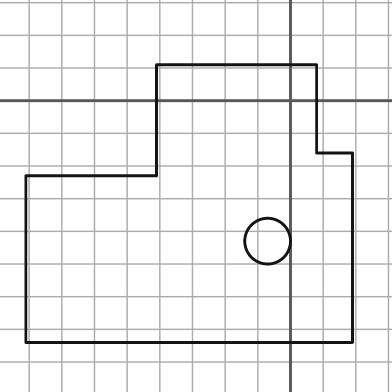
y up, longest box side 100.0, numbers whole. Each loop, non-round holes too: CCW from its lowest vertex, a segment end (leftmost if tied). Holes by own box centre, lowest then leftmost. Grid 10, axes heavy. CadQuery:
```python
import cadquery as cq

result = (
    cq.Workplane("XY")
    .moveTo(-81.0, -74.0)
    .lineTo(19.0, -74.0)
    .lineTo(19.0, -16.0)
    .lineTo(8.0, -16.0)
    .lineTo(8.0, 11.0)
    .lineTo(-41.0, 11.0)
    .lineTo(-41.0, -23.0)
    .lineTo(-81.0, -23.0)
    .close()
    .moveTo(-7.0, -43.0)
    .circle(7.0)
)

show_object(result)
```